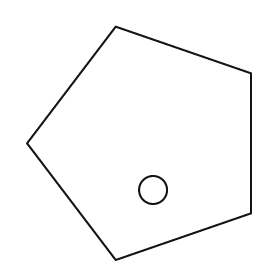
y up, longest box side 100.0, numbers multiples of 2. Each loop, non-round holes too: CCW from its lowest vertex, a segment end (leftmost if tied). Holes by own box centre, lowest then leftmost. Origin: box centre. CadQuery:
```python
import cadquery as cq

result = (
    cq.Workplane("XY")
    .moveTo(-10.0, -50.0)
    .lineTo(48.0, -30.0)
    .lineTo(48.0, 30.0)
    .lineTo(-10.0, 50.0)
    .lineTo(-48.0, 0.0)
    .close()
    .moveTo(6.0, -20.0)
    .circle(6.0)
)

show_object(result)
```